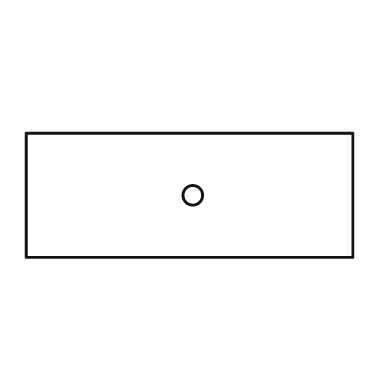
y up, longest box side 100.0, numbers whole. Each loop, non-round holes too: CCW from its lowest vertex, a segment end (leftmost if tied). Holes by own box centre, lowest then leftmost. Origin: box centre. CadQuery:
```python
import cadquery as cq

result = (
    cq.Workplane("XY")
    .moveTo(-50.0, -19.0)
    .lineTo(50.0, -19.0)
    .lineTo(50.0, 19.0)
    .lineTo(-50.0, 19.0)
    .close()
    .moveTo(1.0, 0.0)
    .circle(3.0)
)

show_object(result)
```